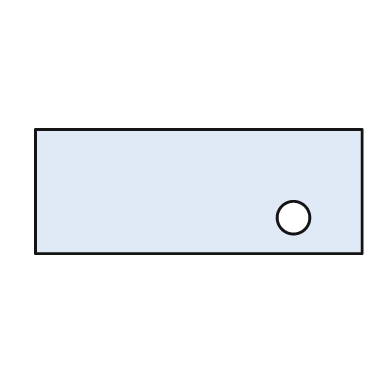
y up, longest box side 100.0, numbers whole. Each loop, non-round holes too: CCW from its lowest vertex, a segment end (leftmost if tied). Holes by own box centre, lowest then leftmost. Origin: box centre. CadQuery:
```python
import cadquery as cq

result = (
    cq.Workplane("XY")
    .moveTo(-50.0, -19.0)
    .lineTo(50.0, -19.0)
    .lineTo(50.0, 19.0)
    .lineTo(-50.0, 19.0)
    .close()
    .moveTo(29.0, -8.0)
    .circle(5.0)
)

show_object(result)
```